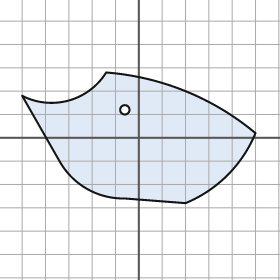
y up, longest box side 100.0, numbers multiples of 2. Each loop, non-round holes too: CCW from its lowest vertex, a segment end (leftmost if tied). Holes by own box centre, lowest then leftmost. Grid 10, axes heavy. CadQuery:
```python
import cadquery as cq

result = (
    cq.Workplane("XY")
    .moveTo(20.0, -28.0)
    .threePointArc((38.0, -16.0), (50.0, 2.0))
    .threePointArc((20.0, 20.0), (-14.0, 28.0))
    .threePointArc((-30.0, 16.0), (-50.0, 18.0))
    .lineTo(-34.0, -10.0)
    .threePointArc((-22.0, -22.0), (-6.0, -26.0))
    .close()
    .moveTo(-6.0, 12.0)
    .circle(2.0)
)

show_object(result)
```